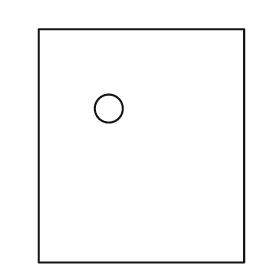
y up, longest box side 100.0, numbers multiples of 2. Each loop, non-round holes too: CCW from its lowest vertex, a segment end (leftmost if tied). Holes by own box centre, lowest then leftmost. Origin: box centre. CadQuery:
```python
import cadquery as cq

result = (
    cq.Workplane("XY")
    .moveTo(-44.0, -50.0)
    .lineTo(44.0, -50.0)
    .lineTo(44.0, 50.0)
    .lineTo(-44.0, 50.0)
    .close()
    .moveTo(-14.0, 16.0)
    .circle(6.0)
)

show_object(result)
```